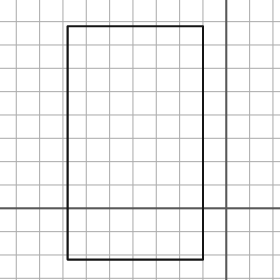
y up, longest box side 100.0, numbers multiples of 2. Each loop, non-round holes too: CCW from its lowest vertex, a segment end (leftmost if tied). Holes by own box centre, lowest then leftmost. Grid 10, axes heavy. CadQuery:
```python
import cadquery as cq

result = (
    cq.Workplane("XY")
    .moveTo(-68.0, -22.0)
    .lineTo(-10.0, -22.0)
    .lineTo(-10.0, 78.0)
    .lineTo(-68.0, 78.0)
    .close()
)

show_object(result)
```